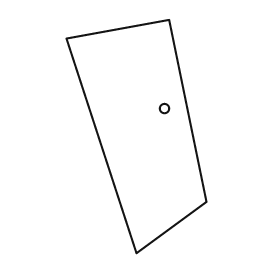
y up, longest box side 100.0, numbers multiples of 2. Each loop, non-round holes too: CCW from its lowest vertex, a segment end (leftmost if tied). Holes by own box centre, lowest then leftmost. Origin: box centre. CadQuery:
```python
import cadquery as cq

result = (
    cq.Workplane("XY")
    .moveTo(0.0, -50.0)
    .lineTo(30.0, -28.0)
    .lineTo(14.0, 50.0)
    .lineTo(-30.0, 42.0)
    .close()
    .moveTo(12.0, 12.0)
    .circle(2.0)
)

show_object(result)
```